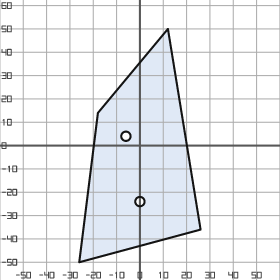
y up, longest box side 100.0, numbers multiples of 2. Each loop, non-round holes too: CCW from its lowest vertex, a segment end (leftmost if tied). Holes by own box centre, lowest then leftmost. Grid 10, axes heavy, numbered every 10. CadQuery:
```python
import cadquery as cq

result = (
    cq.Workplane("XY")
    .moveTo(-26.0, -50.0)
    .lineTo(26.0, -36.0)
    .lineTo(12.0, 50.0)
    .lineTo(-18.0, 14.0)
    .close()
    .moveTo(0.0, -24.0)
    .circle(2.0)
    .moveTo(-6.0, 4.0)
    .circle(2.0)
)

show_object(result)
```